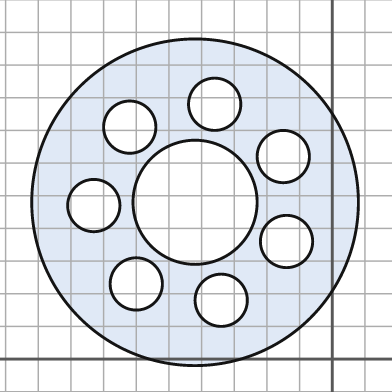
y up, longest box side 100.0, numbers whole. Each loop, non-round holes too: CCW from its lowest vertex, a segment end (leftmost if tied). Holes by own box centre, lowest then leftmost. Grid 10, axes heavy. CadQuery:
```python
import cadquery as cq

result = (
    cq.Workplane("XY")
    .moveTo(-42.0, 48.0)
    .circle(50.0)
    .moveTo(-34.0, 18.0)
    .circle(8.0)
    .moveTo(-60.0, 23.0)
    .circle(8.0)
    .moveTo(-14.0, 36.0)
    .circle(8.0)
    .moveTo(-73.0, 47.0)
    .circle(8.0)
    .moveTo(-42.0, 48.0)
    .circle(19.0)
    .moveTo(-15.0, 62.0)
    .circle(8.0)
    .moveTo(-62.0, 71.0)
    .circle(8.0)
    .moveTo(-36.0, 78.0)
    .circle(8.0)
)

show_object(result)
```